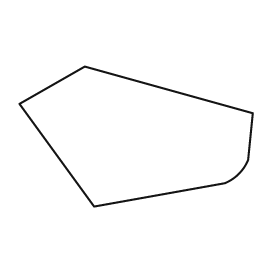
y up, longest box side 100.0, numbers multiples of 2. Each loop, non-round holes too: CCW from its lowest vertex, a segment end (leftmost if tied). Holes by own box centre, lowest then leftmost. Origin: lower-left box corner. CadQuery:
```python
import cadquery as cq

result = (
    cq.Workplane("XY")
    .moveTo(32.0, 0.0)
    .lineTo(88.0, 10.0)
    .threePointArc((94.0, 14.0), (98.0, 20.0))
    .lineTo(100.0, 40.0)
    .lineTo(28.0, 60.0)
    .lineTo(0.0, 44.0)
    .close()
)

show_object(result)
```